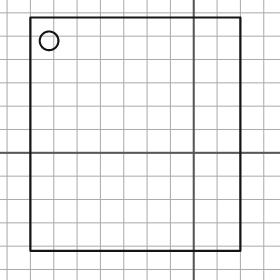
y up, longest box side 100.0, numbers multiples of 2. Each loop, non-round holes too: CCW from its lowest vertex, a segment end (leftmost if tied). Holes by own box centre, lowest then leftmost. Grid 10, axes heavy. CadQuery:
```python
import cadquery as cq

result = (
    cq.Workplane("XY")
    .moveTo(-70.0, -42.0)
    .lineTo(20.0, -42.0)
    .lineTo(20.0, 58.0)
    .lineTo(-70.0, 58.0)
    .close()
    .moveTo(-62.0, 48.0)
    .circle(4.0)
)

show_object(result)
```